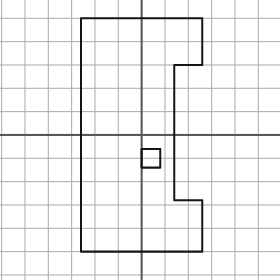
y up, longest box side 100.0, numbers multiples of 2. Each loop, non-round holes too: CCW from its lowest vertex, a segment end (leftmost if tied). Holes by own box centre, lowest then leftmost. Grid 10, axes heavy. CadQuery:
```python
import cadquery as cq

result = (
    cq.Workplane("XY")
    .moveTo(-26.0, -50.0)
    .lineTo(26.0, -50.0)
    .lineTo(26.0, -28.0)
    .lineTo(14.0, -28.0)
    .lineTo(14.0, 30.0)
    .lineTo(26.0, 30.0)
    .lineTo(26.0, 50.0)
    .lineTo(-26.0, 50.0)
    .close()
    .moveTo(0.0, -14.0)
    .lineTo(8.0, -14.0)
    .lineTo(8.0, -6.0)
    .lineTo(0.0, -6.0)
    .close()
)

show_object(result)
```